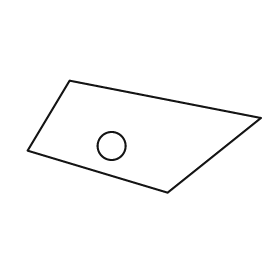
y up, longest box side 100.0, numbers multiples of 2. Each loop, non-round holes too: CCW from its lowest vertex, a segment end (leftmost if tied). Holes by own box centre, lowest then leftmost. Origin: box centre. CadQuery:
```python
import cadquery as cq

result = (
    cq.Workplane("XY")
    .moveTo(10.0, -24.0)
    .lineTo(50.0, 8.0)
    .lineTo(-32.0, 24.0)
    .lineTo(-50.0, -6.0)
    .close()
    .moveTo(-14.0, -4.0)
    .circle(6.0)
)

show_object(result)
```